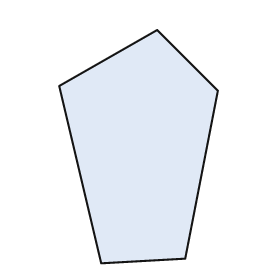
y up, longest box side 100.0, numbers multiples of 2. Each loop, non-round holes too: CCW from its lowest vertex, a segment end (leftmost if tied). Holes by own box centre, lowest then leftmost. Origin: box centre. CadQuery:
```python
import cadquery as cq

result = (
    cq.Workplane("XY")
    .moveTo(-16.0, -50.0)
    .lineTo(20.0, -48.0)
    .lineTo(34.0, 24.0)
    .lineTo(8.0, 50.0)
    .lineTo(-34.0, 26.0)
    .close()
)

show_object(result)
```